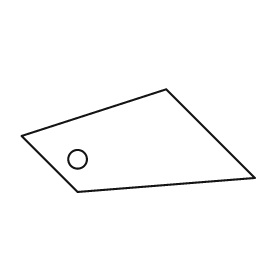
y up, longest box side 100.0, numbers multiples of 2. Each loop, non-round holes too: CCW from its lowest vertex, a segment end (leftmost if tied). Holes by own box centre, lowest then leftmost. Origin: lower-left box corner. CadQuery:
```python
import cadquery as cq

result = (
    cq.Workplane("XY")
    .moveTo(24.0, 0.0)
    .lineTo(100.0, 6.0)
    .lineTo(62.0, 44.0)
    .lineTo(0.0, 24.0)
    .close()
    .moveTo(24.0, 14.0)
    .circle(4.0)
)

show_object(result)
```